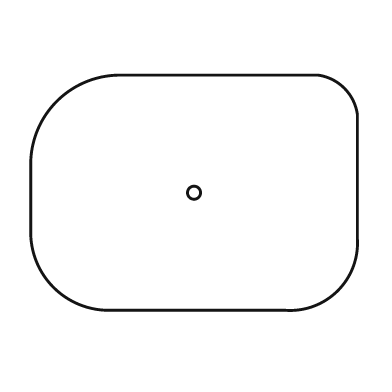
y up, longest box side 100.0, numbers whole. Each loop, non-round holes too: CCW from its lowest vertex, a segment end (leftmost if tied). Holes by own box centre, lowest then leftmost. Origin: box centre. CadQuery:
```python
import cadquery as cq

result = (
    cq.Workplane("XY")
    .moveTo(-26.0, -36.0)
    .lineTo(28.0, -36.0)
    .threePointArc((44.0, -30.0), (50.0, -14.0))
    .lineTo(50.0, 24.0)
    .threePointArc((46.0, 32.0), (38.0, 36.0))
    .lineTo(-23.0, 36.0)
    .threePointArc((-42.0, 28.0), (-50.0, 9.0))
    .lineTo(-50.0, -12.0)
    .threePointArc((-43.0, -29.0), (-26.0, -36.0))
    .close()
    .moveTo(0.0, 0.0)
    .circle(2.0)
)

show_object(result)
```